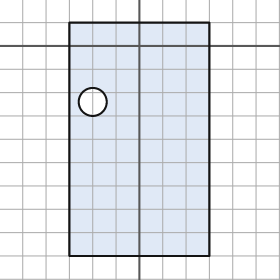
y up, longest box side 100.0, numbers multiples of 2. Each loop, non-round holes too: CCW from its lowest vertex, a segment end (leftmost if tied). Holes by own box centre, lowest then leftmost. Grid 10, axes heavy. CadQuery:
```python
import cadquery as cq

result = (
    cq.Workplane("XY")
    .moveTo(-30.0, -90.0)
    .lineTo(30.0, -90.0)
    .lineTo(30.0, 10.0)
    .lineTo(-30.0, 10.0)
    .close()
    .moveTo(-20.0, -24.0)
    .circle(6.0)
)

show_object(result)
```